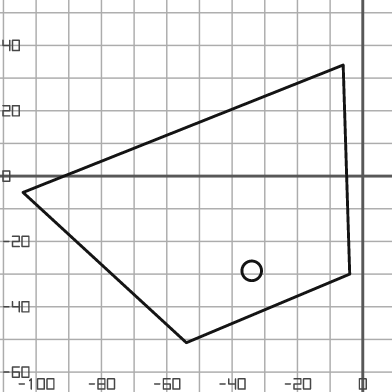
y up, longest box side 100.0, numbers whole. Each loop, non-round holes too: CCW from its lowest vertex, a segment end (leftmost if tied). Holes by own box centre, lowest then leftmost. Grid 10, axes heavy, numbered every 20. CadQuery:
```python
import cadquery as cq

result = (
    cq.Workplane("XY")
    .moveTo(-54.0, -51.0)
    .lineTo(-4.0, -30.0)
    .lineTo(-6.0, 34.0)
    .lineTo(-104.0, -5.0)
    .close()
    .moveTo(-34.0, -29.0)
    .circle(3.0)
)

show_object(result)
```